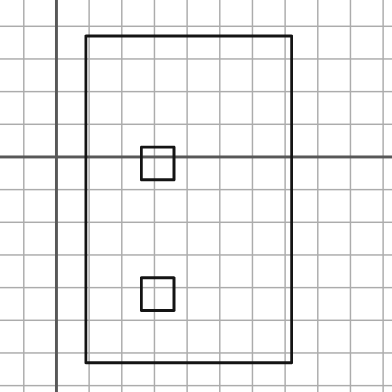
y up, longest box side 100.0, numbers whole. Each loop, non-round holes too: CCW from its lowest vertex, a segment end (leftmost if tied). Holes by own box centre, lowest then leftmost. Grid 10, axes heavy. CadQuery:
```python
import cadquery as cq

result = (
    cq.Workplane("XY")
    .moveTo(9.0, -63.0)
    .lineTo(72.0, -63.0)
    .lineTo(72.0, 37.0)
    .lineTo(9.0, 37.0)
    .close()
    .moveTo(26.0, -47.0)
    .lineTo(36.0, -47.0)
    .lineTo(36.0, -37.0)
    .lineTo(26.0, -37.0)
    .close()
    .moveTo(26.0, -7.0)
    .lineTo(36.0, -7.0)
    .lineTo(36.0, 3.0)
    .lineTo(26.0, 3.0)
    .close()
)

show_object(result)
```